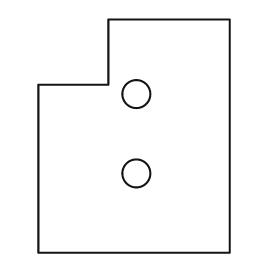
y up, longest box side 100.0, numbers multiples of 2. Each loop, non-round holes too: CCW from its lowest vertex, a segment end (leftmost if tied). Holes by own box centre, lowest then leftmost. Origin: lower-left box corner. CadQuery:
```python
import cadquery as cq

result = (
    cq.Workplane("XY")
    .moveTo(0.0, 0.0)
    .lineTo(82.0, 0.0)
    .lineTo(82.0, 100.0)
    .lineTo(30.0, 100.0)
    .lineTo(30.0, 72.0)
    .lineTo(0.0, 72.0)
    .close()
    .moveTo(42.0, 34.0)
    .circle(6.0)
    .moveTo(42.0, 68.0)
    .circle(6.0)
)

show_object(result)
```